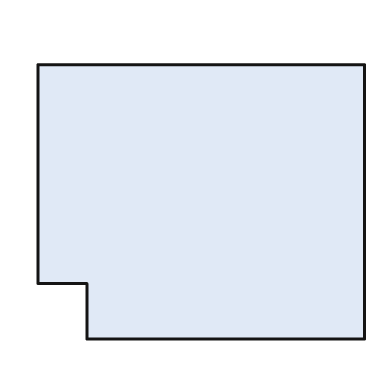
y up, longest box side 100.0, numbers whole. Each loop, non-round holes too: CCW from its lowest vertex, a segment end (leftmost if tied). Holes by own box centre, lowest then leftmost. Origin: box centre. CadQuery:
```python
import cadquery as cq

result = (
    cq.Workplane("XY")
    .moveTo(-35.0, -42.0)
    .lineTo(50.0, -42.0)
    .lineTo(50.0, 42.0)
    .lineTo(-50.0, 42.0)
    .lineTo(-50.0, -25.0)
    .lineTo(-35.0, -25.0)
    .close()
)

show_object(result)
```